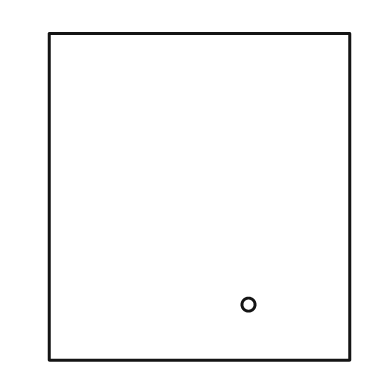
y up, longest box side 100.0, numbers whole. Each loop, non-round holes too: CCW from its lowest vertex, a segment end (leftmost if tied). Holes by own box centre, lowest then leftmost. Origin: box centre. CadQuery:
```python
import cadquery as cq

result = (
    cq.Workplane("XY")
    .moveTo(-46.0, -50.0)
    .lineTo(46.0, -50.0)
    .lineTo(46.0, 50.0)
    .lineTo(-46.0, 50.0)
    .close()
    .moveTo(15.0, -33.0)
    .circle(2.0)
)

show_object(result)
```